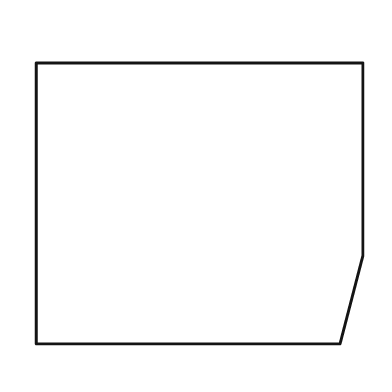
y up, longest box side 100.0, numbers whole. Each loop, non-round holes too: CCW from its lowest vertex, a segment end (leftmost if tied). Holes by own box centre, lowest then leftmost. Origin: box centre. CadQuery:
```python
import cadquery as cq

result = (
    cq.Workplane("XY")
    .moveTo(-50.0, -43.0)
    .lineTo(43.0, -43.0)
    .lineTo(50.0, -16.0)
    .lineTo(50.0, 43.0)
    .lineTo(-50.0, 43.0)
    .close()
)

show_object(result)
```